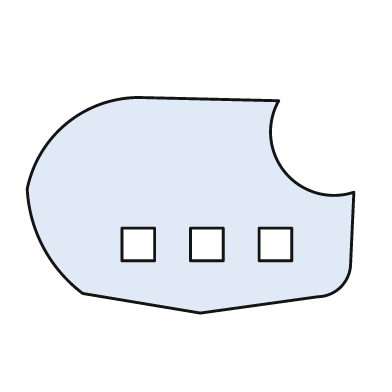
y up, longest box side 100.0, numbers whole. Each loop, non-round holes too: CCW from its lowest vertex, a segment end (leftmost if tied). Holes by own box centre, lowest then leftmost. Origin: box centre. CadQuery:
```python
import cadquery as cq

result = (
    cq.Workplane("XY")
    .moveTo(3.0, -33.0)
    .lineTo(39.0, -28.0)
    .threePointArc((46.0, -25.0), (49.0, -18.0))
    .lineTo(50.0, 4.0)
    .threePointArc((29.0, 10.0), (27.0, 32.0))
    .lineTo(-16.0, 33.0)
    .threePointArc((-38.0, 25.0), (-50.0, 5.0))
    .threePointArc((-45.0, -13.0), (-33.0, -27.0))
    .close()
    .moveTo(-21.0, -17.0)
    .lineTo(-11.0, -17.0)
    .lineTo(-11.0, -7.0)
    .lineTo(-21.0, -7.0)
    .close()
    .moveTo(0.0, -17.0)
    .lineTo(10.0, -17.0)
    .lineTo(10.0, -7.0)
    .lineTo(0.0, -7.0)
    .close()
    .moveTo(21.0, -17.0)
    .lineTo(31.0, -17.0)
    .lineTo(31.0, -7.0)
    .lineTo(21.0, -7.0)
    .close()
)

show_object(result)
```